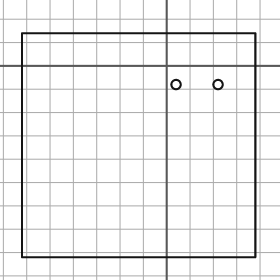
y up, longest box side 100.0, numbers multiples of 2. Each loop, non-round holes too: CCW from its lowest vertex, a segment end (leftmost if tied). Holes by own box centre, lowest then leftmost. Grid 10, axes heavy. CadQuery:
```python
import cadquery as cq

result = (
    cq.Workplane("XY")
    .moveTo(-62.0, -82.0)
    .lineTo(38.0, -82.0)
    .lineTo(38.0, 14.0)
    .lineTo(-62.0, 14.0)
    .close()
    .moveTo(4.0, -8.0)
    .circle(2.0)
    .moveTo(22.0, -8.0)
    .circle(2.0)
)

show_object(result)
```